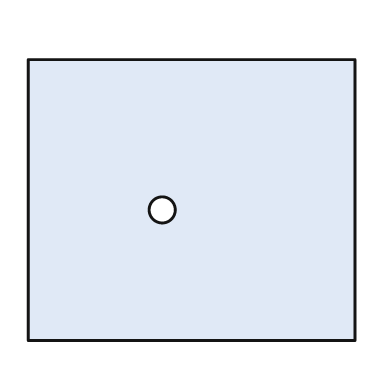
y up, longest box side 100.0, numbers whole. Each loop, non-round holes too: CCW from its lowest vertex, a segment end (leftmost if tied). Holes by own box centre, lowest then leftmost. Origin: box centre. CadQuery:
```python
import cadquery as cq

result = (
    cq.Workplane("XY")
    .moveTo(-50.0, -43.0)
    .lineTo(50.0, -43.0)
    .lineTo(50.0, 43.0)
    .lineTo(-50.0, 43.0)
    .close()
    .moveTo(-9.0, -3.0)
    .circle(4.0)
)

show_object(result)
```